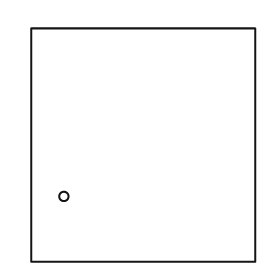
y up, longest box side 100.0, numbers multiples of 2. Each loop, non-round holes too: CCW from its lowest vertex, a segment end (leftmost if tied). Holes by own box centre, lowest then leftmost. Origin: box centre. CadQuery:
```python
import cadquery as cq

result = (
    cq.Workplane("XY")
    .moveTo(-48.0, -50.0)
    .lineTo(48.0, -50.0)
    .lineTo(48.0, 50.0)
    .lineTo(-48.0, 50.0)
    .close()
    .moveTo(-34.0, -22.0)
    .circle(2.0)
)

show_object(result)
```